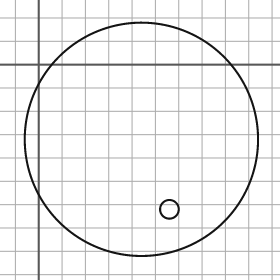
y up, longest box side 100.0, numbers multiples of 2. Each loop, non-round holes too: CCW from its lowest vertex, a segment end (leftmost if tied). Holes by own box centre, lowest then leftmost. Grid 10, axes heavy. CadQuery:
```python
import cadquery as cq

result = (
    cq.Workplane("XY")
    .moveTo(44.0, -32.0)
    .circle(50.0)
    .moveTo(56.0, -62.0)
    .circle(4.0)
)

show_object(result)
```